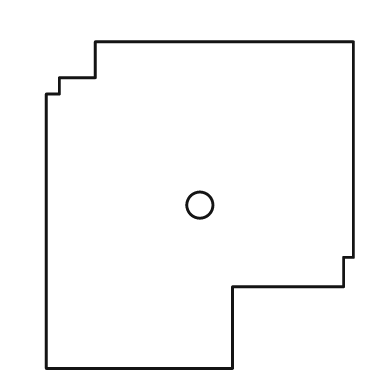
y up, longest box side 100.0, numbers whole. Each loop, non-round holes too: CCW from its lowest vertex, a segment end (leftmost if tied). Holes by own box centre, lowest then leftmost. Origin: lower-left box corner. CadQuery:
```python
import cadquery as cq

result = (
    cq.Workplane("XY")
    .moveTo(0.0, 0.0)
    .lineTo(57.0, 0.0)
    .lineTo(57.0, 25.0)
    .lineTo(91.0, 25.0)
    .lineTo(91.0, 34.0)
    .lineTo(94.0, 34.0)
    .lineTo(94.0, 100.0)
    .lineTo(15.0, 100.0)
    .lineTo(15.0, 89.0)
    .lineTo(4.0, 89.0)
    .lineTo(4.0, 84.0)
    .lineTo(0.0, 84.0)
    .close()
    .moveTo(47.0, 50.0)
    .circle(4.0)
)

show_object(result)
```